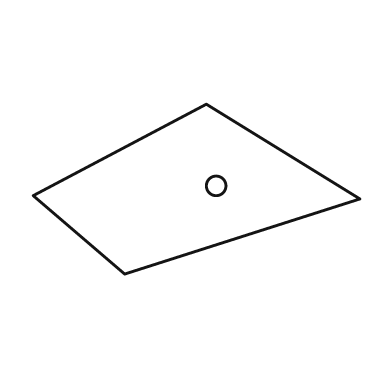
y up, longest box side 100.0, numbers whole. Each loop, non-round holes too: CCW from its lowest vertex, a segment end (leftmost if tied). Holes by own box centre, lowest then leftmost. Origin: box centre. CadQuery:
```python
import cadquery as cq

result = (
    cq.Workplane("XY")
    .moveTo(-22.0, -26.0)
    .lineTo(50.0, -3.0)
    .lineTo(3.0, 26.0)
    .lineTo(-50.0, -2.0)
    .close()
    .moveTo(6.0, 1.0)
    .circle(3.0)
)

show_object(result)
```